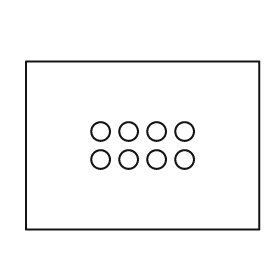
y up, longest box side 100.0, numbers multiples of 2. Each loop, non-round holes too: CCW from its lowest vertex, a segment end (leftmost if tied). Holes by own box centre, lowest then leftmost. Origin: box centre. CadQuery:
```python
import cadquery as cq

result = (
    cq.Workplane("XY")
    .moveTo(-50.0, -36.0)
    .lineTo(50.0, -36.0)
    .lineTo(50.0, 36.0)
    .lineTo(-50.0, 36.0)
    .close()
    .moveTo(-18.0, -6.0)
    .circle(4.0)
    .moveTo(-6.0, -6.0)
    .circle(4.0)
    .moveTo(6.0, -6.0)
    .circle(4.0)
    .moveTo(18.0, -6.0)
    .circle(4.0)
    .moveTo(-18.0, 6.0)
    .circle(4.0)
    .moveTo(-6.0, 6.0)
    .circle(4.0)
    .moveTo(6.0, 6.0)
    .circle(4.0)
    .moveTo(18.0, 6.0)
    .circle(4.0)
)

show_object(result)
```